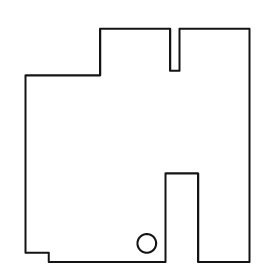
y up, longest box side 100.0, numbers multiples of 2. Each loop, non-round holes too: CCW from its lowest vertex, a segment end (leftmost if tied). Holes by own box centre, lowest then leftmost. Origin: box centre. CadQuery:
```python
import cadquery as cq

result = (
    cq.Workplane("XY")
    .moveTo(-38.0, -50.0)
    .lineTo(12.0, -50.0)
    .lineTo(12.0, -12.0)
    .lineTo(26.0, -12.0)
    .lineTo(26.0, -50.0)
    .lineTo(48.0, -50.0)
    .lineTo(48.0, 50.0)
    .lineTo(18.0, 50.0)
    .lineTo(18.0, 32.0)
    .lineTo(14.0, 32.0)
    .lineTo(14.0, 50.0)
    .lineTo(-16.0, 50.0)
    .lineTo(-16.0, 30.0)
    .lineTo(-48.0, 30.0)
    .lineTo(-48.0, -46.0)
    .lineTo(-38.0, -46.0)
    .close()
    .moveTo(4.0, -42.0)
    .circle(4.0)
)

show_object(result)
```